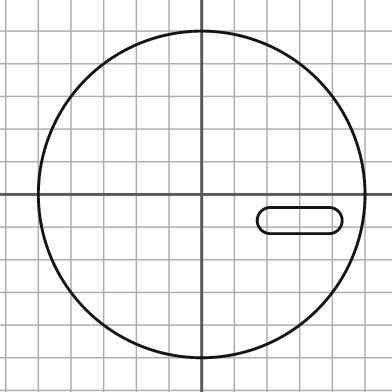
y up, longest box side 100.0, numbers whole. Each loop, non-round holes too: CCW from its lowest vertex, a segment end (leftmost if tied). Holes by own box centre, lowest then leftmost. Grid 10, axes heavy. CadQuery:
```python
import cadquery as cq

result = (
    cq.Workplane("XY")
    .moveTo(0.0, 0.0)
    .circle(50.0)
    .moveTo(21.0, -12.0)
    .lineTo(39.0, -12.0)
    .threePointArc((43.0, -8.0), (39.0, -4.0))
    .lineTo(21.0, -4.0)
    .threePointArc((17.0, -8.0), (21.0, -12.0))
    .close()
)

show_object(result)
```